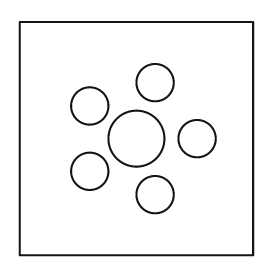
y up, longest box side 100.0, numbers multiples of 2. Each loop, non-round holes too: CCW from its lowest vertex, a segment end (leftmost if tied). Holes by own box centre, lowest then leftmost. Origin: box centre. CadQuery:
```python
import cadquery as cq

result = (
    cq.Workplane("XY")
    .moveTo(-50.0, -50.0)
    .lineTo(50.0, -50.0)
    .lineTo(50.0, 50.0)
    .lineTo(-50.0, 50.0)
    .close()
    .moveTo(8.0, -24.0)
    .circle(8.0)
    .moveTo(-20.0, -14.0)
    .circle(8.0)
    .moveTo(0.0, 0.0)
    .circle(12.0)
    .moveTo(26.0, 0.0)
    .circle(8.0)
    .moveTo(-20.0, 14.0)
    .circle(8.0)
    .moveTo(8.0, 24.0)
    .circle(8.0)
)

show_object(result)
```